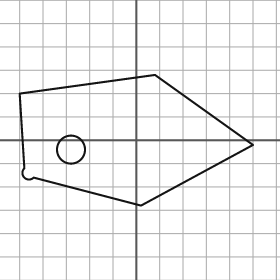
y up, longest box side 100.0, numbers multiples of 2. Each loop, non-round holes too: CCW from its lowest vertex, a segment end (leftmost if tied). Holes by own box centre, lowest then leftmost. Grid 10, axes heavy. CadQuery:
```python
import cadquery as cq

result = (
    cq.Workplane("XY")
    .moveTo(2.0, -28.0)
    .lineTo(50.0, -2.0)
    .lineTo(8.0, 28.0)
    .lineTo(-50.0, 20.0)
    .lineTo(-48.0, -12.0)
    .threePointArc((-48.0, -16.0), (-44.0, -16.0))
    .close()
    .moveTo(-28.0, -4.0)
    .circle(6.0)
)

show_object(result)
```